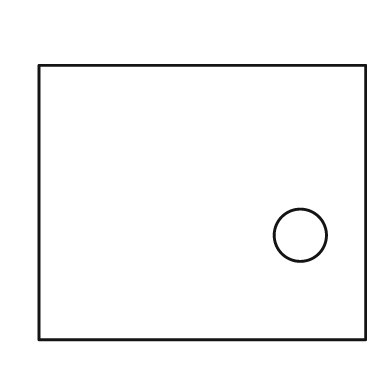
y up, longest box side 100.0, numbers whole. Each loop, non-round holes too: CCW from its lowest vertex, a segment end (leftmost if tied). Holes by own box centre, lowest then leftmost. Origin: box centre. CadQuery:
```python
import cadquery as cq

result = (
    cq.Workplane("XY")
    .moveTo(-50.0, -42.0)
    .lineTo(50.0, -42.0)
    .lineTo(50.0, 42.0)
    .lineTo(-50.0, 42.0)
    .close()
    .moveTo(30.0, -10.0)
    .circle(8.0)
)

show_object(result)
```